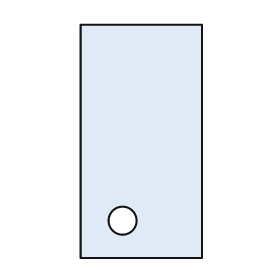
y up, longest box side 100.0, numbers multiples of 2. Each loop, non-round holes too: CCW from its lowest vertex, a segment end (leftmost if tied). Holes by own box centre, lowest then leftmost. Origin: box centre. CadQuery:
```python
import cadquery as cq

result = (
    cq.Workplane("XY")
    .moveTo(-26.0, -50.0)
    .lineTo(26.0, -50.0)
    .lineTo(26.0, 50.0)
    .lineTo(-26.0, 50.0)
    .close()
    .moveTo(-8.0, -34.0)
    .circle(6.0)
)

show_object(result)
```